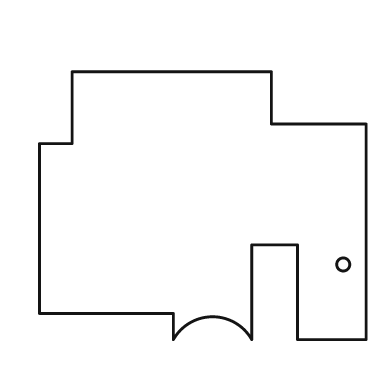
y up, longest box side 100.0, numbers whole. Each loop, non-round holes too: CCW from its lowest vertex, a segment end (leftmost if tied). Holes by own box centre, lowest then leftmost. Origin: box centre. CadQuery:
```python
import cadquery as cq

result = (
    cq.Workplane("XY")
    .moveTo(-9.0, -41.0)
    .threePointArc((3.0, -34.0), (15.0, -41.0))
    .lineTo(15.0, -12.0)
    .lineTo(29.0, -12.0)
    .lineTo(29.0, -41.0)
    .lineTo(50.0, -41.0)
    .lineTo(50.0, 25.0)
    .lineTo(21.0, 25.0)
    .lineTo(21.0, 41.0)
    .lineTo(-40.0, 41.0)
    .lineTo(-40.0, 19.0)
    .lineTo(-50.0, 19.0)
    .lineTo(-50.0, -33.0)
    .lineTo(-9.0, -33.0)
    .close()
    .moveTo(43.0, -18.0)
    .circle(2.0)
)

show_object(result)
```